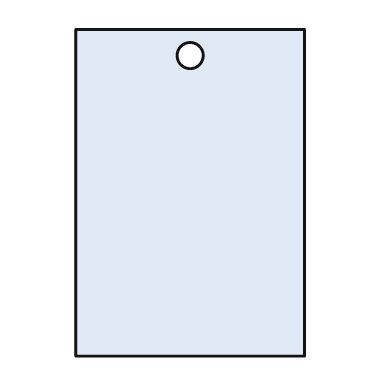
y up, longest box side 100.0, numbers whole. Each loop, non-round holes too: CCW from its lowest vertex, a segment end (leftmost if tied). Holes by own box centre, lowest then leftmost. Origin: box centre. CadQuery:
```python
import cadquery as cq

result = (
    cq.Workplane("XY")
    .moveTo(-35.0, -50.0)
    .lineTo(35.0, -50.0)
    .lineTo(35.0, 50.0)
    .lineTo(-35.0, 50.0)
    .close()
    .moveTo(0.0, 42.0)
    .circle(4.0)
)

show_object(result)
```